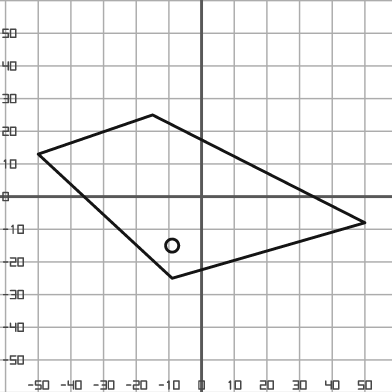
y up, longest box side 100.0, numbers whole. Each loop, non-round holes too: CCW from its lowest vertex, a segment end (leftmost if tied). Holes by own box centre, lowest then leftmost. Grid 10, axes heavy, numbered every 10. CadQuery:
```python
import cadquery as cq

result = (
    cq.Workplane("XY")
    .moveTo(-9.0, -25.0)
    .lineTo(50.0, -8.0)
    .lineTo(-15.0, 25.0)
    .lineTo(-50.0, 13.0)
    .close()
    .moveTo(-9.0, -15.0)
    .circle(2.0)
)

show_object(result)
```